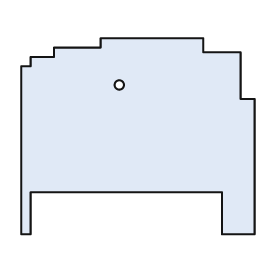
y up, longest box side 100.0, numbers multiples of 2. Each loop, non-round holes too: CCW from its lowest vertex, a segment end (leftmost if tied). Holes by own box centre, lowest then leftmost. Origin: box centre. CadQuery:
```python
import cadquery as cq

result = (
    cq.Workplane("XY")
    .moveTo(-50.0, -42.0)
    .lineTo(-46.0, -42.0)
    .lineTo(-46.0, -24.0)
    .lineTo(36.0, -24.0)
    .lineTo(36.0, -42.0)
    .lineTo(50.0, -42.0)
    .lineTo(50.0, 16.0)
    .lineTo(44.0, 16.0)
    .lineTo(44.0, 36.0)
    .lineTo(28.0, 36.0)
    .lineTo(28.0, 42.0)
    .lineTo(-16.0, 42.0)
    .lineTo(-16.0, 38.0)
    .lineTo(-36.0, 38.0)
    .lineTo(-36.0, 34.0)
    .lineTo(-46.0, 34.0)
    .lineTo(-46.0, 30.0)
    .lineTo(-50.0, 30.0)
    .close()
    .moveTo(-8.0, 22.0)
    .circle(2.0)
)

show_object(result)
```